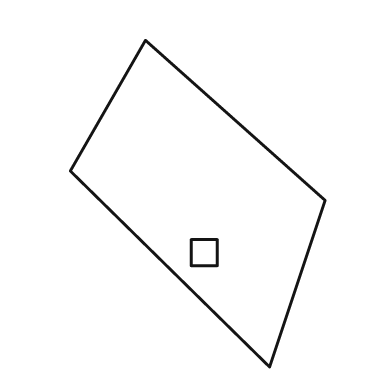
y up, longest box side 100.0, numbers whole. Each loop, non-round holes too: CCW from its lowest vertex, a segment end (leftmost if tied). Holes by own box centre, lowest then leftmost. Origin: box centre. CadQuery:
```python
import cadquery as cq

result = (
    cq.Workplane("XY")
    .moveTo(22.0, -50.0)
    .lineTo(39.0, 1.0)
    .lineTo(-16.0, 50.0)
    .lineTo(-39.0, 10.0)
    .close()
    .moveTo(-2.0, -19.0)
    .lineTo(6.0, -19.0)
    .lineTo(6.0, -11.0)
    .lineTo(-2.0, -11.0)
    .close()
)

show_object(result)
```